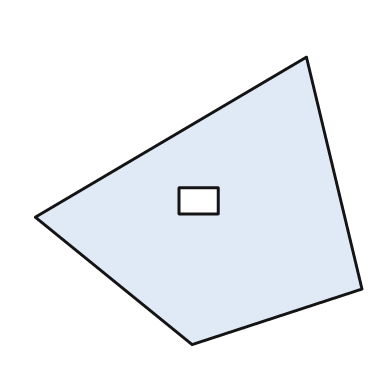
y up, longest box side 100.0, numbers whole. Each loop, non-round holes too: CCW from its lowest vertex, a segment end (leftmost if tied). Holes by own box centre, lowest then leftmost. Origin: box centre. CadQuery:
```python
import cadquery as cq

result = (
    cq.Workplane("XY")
    .moveTo(-2.0, -44.0)
    .lineTo(50.0, -27.0)
    .lineTo(33.0, 44.0)
    .lineTo(-50.0, -5.0)
    .close()
    .moveTo(-6.0, -4.0)
    .lineTo(6.0, -4.0)
    .lineTo(6.0, 4.0)
    .lineTo(-6.0, 4.0)
    .close()
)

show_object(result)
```